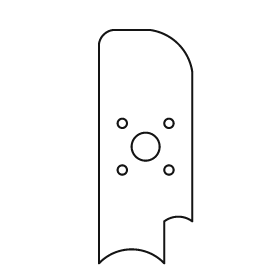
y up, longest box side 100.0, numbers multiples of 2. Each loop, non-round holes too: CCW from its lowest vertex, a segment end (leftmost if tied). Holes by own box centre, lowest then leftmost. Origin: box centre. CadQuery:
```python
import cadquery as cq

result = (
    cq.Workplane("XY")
    .moveTo(-20.0, -50.0)
    .threePointArc((-6.0, -44.0), (8.0, -50.0))
    .lineTo(8.0, -32.0)
    .threePointArc((14.0, -30.0), (20.0, -32.0))
    .lineTo(20.0, 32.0)
    .threePointArc((14.0, 44.0), (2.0, 50.0))
    .lineTo(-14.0, 50.0)
    .threePointArc((-18.0, 48.0), (-20.0, 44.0))
    .close()
    .moveTo(-10.0, -10.0)
    .circle(2.0)
    .moveTo(10.0, -10.0)
    .circle(2.0)
    .moveTo(0.0, 0.0)
    .circle(6.0)
    .moveTo(-10.0, 10.0)
    .circle(2.0)
    .moveTo(10.0, 10.0)
    .circle(2.0)
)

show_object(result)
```